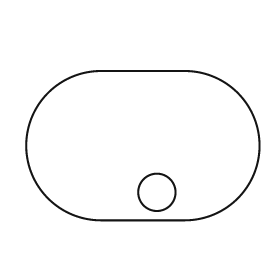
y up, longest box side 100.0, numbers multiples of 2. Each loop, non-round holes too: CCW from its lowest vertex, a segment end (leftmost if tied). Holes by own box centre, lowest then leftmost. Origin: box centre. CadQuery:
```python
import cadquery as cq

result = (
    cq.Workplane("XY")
    .moveTo(-18.0, -32.0)
    .lineTo(18.0, -32.0)
    .threePointArc((50.0, 0.0), (18.0, 32.0))
    .lineTo(-18.0, 32.0)
    .threePointArc((-50.0, 0.0), (-18.0, -32.0))
    .close()
    .moveTo(6.0, -20.0)
    .circle(8.0)
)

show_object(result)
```